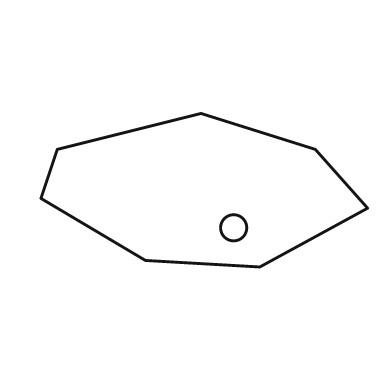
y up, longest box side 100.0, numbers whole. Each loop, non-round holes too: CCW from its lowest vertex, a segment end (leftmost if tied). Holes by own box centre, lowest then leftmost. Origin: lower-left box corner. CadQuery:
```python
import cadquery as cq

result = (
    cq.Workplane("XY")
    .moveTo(67.0, 0.0)
    .lineTo(100.0, 18.0)
    .lineTo(84.0, 36.0)
    .lineTo(49.0, 47.0)
    .lineTo(5.0, 36.0)
    .lineTo(0.0, 21.0)
    .lineTo(32.0, 2.0)
    .close()
    .moveTo(59.0, 12.0)
    .circle(4.0)
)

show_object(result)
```